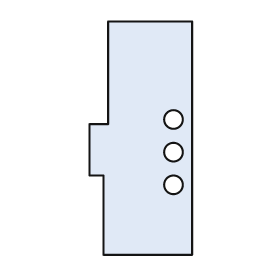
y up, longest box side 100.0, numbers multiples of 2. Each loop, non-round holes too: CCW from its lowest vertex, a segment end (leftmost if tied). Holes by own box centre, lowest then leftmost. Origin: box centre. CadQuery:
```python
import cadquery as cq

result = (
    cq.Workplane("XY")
    .moveTo(-16.0, -50.0)
    .lineTo(22.0, -50.0)
    .lineTo(22.0, 50.0)
    .lineTo(-14.0, 50.0)
    .lineTo(-14.0, 6.0)
    .lineTo(-22.0, 6.0)
    .lineTo(-22.0, -16.0)
    .lineTo(-16.0, -16.0)
    .close()
    .moveTo(14.0, -20.0)
    .circle(4.0)
    .moveTo(14.0, -6.0)
    .circle(4.0)
    .moveTo(14.0, 8.0)
    .circle(4.0)
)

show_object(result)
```